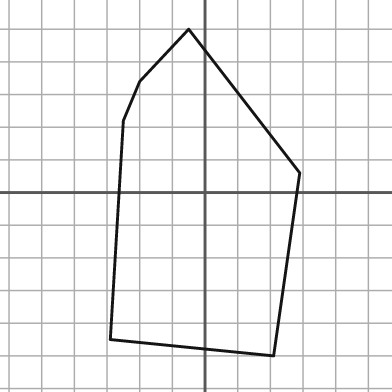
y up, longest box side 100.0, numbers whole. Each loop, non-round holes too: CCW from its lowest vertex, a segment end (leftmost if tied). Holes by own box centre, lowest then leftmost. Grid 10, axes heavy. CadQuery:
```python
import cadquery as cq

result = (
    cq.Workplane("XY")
    .moveTo(21.0, -50.0)
    .lineTo(29.0, 6.0)
    .lineTo(-5.0, 50.0)
    .lineTo(-20.0, 34.0)
    .lineTo(-25.0, 22.0)
    .lineTo(-29.0, -45.0)
    .close()
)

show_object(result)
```